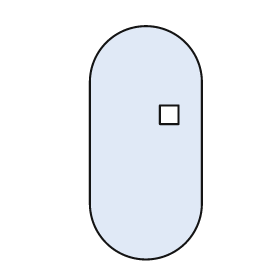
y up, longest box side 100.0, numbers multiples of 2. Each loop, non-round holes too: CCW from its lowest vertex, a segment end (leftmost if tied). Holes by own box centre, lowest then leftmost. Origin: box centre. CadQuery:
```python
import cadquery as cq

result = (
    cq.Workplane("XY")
    .moveTo(-24.0, -26.0)
    .threePointArc((0.0, -50.0), (24.0, -26.0))
    .lineTo(24.0, 26.0)
    .threePointArc((0.0, 50.0), (-24.0, 26.0))
    .close()
    .moveTo(6.0, 8.0)
    .lineTo(14.0, 8.0)
    .lineTo(14.0, 16.0)
    .lineTo(6.0, 16.0)
    .close()
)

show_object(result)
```